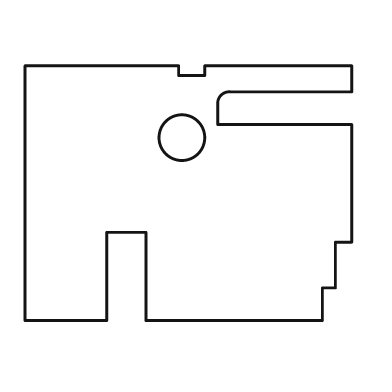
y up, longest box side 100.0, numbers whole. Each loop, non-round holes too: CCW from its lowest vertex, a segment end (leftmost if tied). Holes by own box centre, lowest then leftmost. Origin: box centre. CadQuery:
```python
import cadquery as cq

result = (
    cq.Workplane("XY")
    .moveTo(-50.0, -39.0)
    .lineTo(-25.0, -39.0)
    .lineTo(-25.0, -12.0)
    .lineTo(-13.0, -12.0)
    .lineTo(-13.0, -39.0)
    .lineTo(41.0, -39.0)
    .lineTo(41.0, -29.0)
    .lineTo(45.0, -29.0)
    .lineTo(45.0, -15.0)
    .lineTo(50.0, -15.0)
    .lineTo(50.0, 21.0)
    .lineTo(9.0, 21.0)
    .lineTo(9.0, 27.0)
    .threePointArc((10.0, 30.0), (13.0, 31.0))
    .lineTo(50.0, 31.0)
    .lineTo(50.0, 39.0)
    .lineTo(5.0, 39.0)
    .lineTo(5.0, 36.0)
    .lineTo(-3.0, 36.0)
    .lineTo(-3.0, 39.0)
    .lineTo(-50.0, 39.0)
    .close()
    .moveTo(-2.0, 17.0)
    .circle(7.0)
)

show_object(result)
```